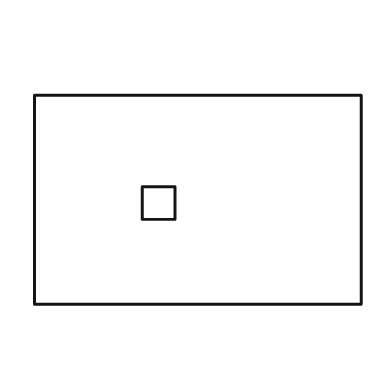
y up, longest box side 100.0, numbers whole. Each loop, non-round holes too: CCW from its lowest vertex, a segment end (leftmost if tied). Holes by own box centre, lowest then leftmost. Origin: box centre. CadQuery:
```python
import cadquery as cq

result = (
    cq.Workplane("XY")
    .moveTo(-50.0, -32.0)
    .lineTo(50.0, -32.0)
    .lineTo(50.0, 32.0)
    .lineTo(-50.0, 32.0)
    .close()
    .moveTo(-17.0, -6.0)
    .lineTo(-7.0, -6.0)
    .lineTo(-7.0, 4.0)
    .lineTo(-17.0, 4.0)
    .close()
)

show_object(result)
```